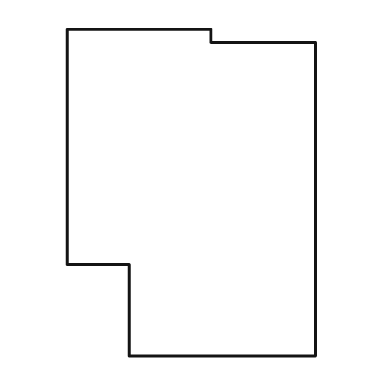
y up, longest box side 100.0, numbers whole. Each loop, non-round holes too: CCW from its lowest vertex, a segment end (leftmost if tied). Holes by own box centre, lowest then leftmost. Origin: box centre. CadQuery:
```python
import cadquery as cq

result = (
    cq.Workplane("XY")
    .moveTo(-19.0, -50.0)
    .lineTo(38.0, -50.0)
    .lineTo(38.0, 46.0)
    .lineTo(6.0, 46.0)
    .lineTo(6.0, 50.0)
    .lineTo(-38.0, 50.0)
    .lineTo(-38.0, -22.0)
    .lineTo(-19.0, -22.0)
    .close()
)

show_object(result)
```